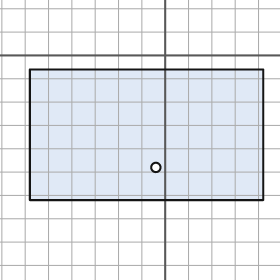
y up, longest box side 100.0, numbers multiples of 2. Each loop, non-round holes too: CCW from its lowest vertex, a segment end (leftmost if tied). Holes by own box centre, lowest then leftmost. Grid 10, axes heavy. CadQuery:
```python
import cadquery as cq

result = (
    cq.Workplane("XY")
    .moveTo(-58.0, -62.0)
    .lineTo(42.0, -62.0)
    .lineTo(42.0, -6.0)
    .lineTo(-58.0, -6.0)
    .close()
    .moveTo(-4.0, -48.0)
    .circle(2.0)
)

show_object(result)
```